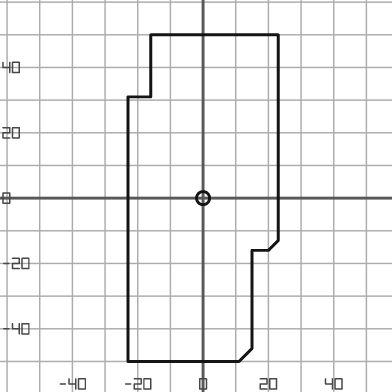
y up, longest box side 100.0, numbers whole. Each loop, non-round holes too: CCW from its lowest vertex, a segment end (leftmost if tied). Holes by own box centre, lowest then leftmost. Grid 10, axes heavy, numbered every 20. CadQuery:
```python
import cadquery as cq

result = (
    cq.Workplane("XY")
    .moveTo(-23.0, -50.0)
    .lineTo(11.0, -50.0)
    .lineTo(15.0, -46.0)
    .lineTo(15.0, -16.0)
    .lineTo(20.0, -16.0)
    .lineTo(23.0, -13.0)
    .lineTo(23.0, 50.0)
    .lineTo(-16.0, 50.0)
    .lineTo(-16.0, 31.0)
    .lineTo(-23.0, 31.0)
    .close()
    .moveTo(0.0, 0.0)
    .circle(2.0)
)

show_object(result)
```